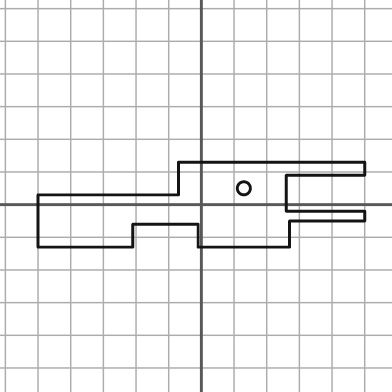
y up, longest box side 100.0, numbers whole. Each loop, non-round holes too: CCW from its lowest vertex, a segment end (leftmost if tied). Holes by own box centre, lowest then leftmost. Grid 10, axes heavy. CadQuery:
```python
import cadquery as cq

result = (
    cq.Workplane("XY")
    .moveTo(-50.0, -13.0)
    .lineTo(-21.0, -13.0)
    .lineTo(-21.0, -6.0)
    .lineTo(-1.0, -6.0)
    .lineTo(-1.0, -13.0)
    .lineTo(27.0, -13.0)
    .lineTo(27.0, -5.0)
    .lineTo(50.0, -5.0)
    .lineTo(50.0, -2.0)
    .lineTo(26.0, -2.0)
    .lineTo(26.0, 9.0)
    .lineTo(50.0, 9.0)
    .lineTo(50.0, 13.0)
    .lineTo(-7.0, 13.0)
    .lineTo(-7.0, 3.0)
    .lineTo(-50.0, 3.0)
    .close()
    .moveTo(13.0, 5.0)
    .circle(2.0)
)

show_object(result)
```